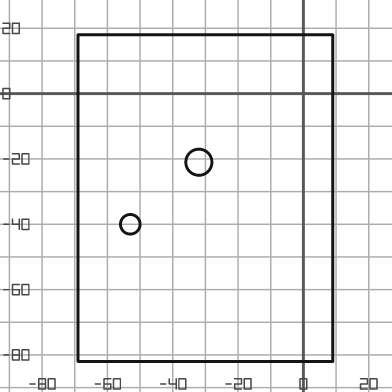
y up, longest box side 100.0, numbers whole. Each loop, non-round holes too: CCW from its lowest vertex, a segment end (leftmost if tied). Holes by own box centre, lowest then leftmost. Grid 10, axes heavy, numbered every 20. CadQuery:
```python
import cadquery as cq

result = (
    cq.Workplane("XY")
    .moveTo(-69.0, -82.0)
    .lineTo(9.0, -82.0)
    .lineTo(9.0, 18.0)
    .lineTo(-69.0, 18.0)
    .close()
    .moveTo(-53.0, -40.0)
    .circle(3.0)
    .moveTo(-32.0, -21.0)
    .circle(4.0)
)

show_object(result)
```